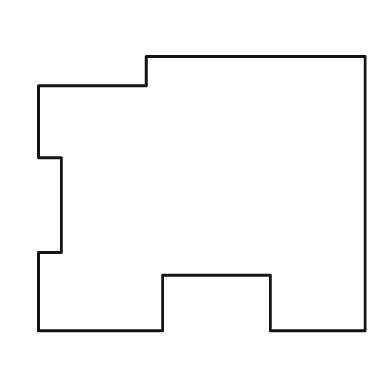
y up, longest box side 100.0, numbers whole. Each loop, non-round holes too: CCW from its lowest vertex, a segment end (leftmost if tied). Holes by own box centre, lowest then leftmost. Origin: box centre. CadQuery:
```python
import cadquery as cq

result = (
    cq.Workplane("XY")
    .moveTo(-50.0, -42.0)
    .lineTo(-12.0, -42.0)
    .lineTo(-12.0, -25.0)
    .lineTo(21.0, -25.0)
    .lineTo(21.0, -42.0)
    .lineTo(50.0, -42.0)
    .lineTo(50.0, 42.0)
    .lineTo(-17.0, 42.0)
    .lineTo(-17.0, 33.0)
    .lineTo(-50.0, 33.0)
    .lineTo(-50.0, 11.0)
    .lineTo(-43.0, 11.0)
    .lineTo(-43.0, -18.0)
    .lineTo(-50.0, -18.0)
    .close()
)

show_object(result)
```